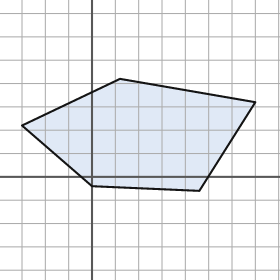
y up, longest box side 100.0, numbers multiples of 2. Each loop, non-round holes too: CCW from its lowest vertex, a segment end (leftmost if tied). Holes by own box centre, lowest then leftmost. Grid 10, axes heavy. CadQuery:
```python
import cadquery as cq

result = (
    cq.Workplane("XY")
    .moveTo(46.0, -6.0)
    .lineTo(70.0, 32.0)
    .lineTo(12.0, 42.0)
    .lineTo(-30.0, 22.0)
    .lineTo(0.0, -4.0)
    .close()
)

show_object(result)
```